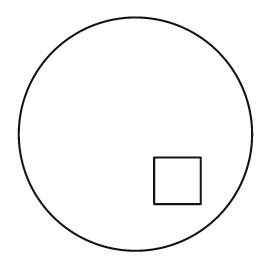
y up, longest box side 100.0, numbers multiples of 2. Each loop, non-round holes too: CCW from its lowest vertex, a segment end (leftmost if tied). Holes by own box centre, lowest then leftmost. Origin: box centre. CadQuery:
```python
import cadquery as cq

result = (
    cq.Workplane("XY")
    .moveTo(0.0, 0.0)
    .circle(50.0)
    .moveTo(8.0, -30.0)
    .lineTo(28.0, -30.0)
    .lineTo(28.0, -10.0)
    .lineTo(8.0, -10.0)
    .close()
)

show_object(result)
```